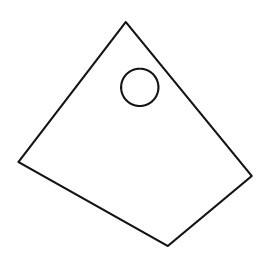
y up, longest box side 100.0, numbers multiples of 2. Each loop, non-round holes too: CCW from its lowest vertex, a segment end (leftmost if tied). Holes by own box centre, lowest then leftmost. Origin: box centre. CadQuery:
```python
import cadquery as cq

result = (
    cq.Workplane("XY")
    .moveTo(14.0, -48.0)
    .lineTo(50.0, -18.0)
    .lineTo(-4.0, 48.0)
    .lineTo(-50.0, -12.0)
    .close()
    .moveTo(2.0, 20.0)
    .circle(8.0)
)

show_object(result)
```